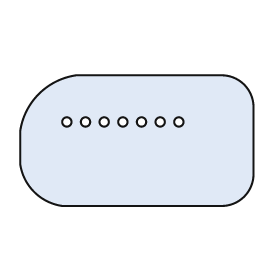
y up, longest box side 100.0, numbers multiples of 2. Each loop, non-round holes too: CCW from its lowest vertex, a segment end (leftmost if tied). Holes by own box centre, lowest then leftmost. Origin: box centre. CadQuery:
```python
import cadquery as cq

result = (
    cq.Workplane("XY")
    .moveTo(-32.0, -28.0)
    .lineTo(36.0, -28.0)
    .threePointArc((46.0, -24.0), (50.0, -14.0))
    .lineTo(50.0, 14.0)
    .threePointArc((46.0, 24.0), (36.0, 28.0))
    .lineTo(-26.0, 28.0)
    .threePointArc((-42.0, 20.0), (-50.0, 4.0))
    .lineTo(-50.0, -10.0)
    .threePointArc((-44.0, -22.0), (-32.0, -28.0))
    .close()
    .moveTo(-30.0, 8.0)
    .circle(2.0)
    .moveTo(-22.0, 8.0)
    .circle(2.0)
    .moveTo(-14.0, 8.0)
    .circle(2.0)
    .moveTo(-6.0, 8.0)
    .circle(2.0)
    .moveTo(2.0, 8.0)
    .circle(2.0)
    .moveTo(10.0, 8.0)
    .circle(2.0)
    .moveTo(18.0, 8.0)
    .circle(2.0)
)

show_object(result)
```